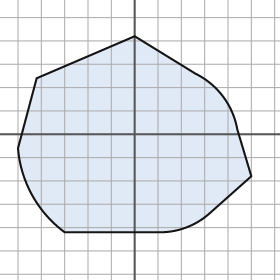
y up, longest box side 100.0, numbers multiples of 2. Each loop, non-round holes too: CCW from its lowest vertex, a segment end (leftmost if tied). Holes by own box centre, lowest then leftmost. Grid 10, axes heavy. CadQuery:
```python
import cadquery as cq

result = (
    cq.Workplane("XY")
    .moveTo(-30.0, -42.0)
    .lineTo(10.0, -42.0)
    .threePointArc((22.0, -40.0), (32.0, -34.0))
    .lineTo(50.0, -18.0)
    .lineTo(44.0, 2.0)
    .threePointArc((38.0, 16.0), (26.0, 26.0))
    .lineTo(0.0, 42.0)
    .lineTo(-42.0, 24.0)
    .lineTo(-50.0, -6.0)
    .threePointArc((-44.0, -26.0), (-30.0, -42.0))
    .close()
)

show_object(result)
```